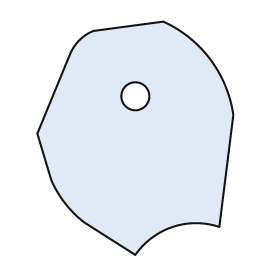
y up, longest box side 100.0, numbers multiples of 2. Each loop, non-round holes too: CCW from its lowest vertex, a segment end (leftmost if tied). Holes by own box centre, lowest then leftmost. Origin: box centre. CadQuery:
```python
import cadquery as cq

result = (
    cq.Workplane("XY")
    .moveTo(0.0, -50.0)
    .threePointArc((16.0, -38.0), (36.0, -38.0))
    .lineTo(42.0, 10.0)
    .threePointArc((32.0, 34.0), (12.0, 50.0))
    .lineTo(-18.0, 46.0)
    .threePointArc((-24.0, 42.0), (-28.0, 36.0))
    .lineTo(-42.0, 2.0)
    .lineTo(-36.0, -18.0)
    .threePointArc((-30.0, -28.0), (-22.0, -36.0))
    .close()
    .moveTo(0.0, 18.0)
    .circle(6.0)
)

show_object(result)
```